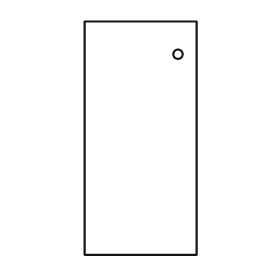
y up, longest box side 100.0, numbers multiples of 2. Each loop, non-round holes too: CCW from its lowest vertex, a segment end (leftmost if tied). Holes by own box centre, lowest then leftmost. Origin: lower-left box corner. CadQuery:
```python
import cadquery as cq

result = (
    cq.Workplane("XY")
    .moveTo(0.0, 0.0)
    .lineTo(48.0, 0.0)
    .lineTo(48.0, 100.0)
    .lineTo(0.0, 100.0)
    .close()
    .moveTo(40.0, 86.0)
    .circle(2.0)
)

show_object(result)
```